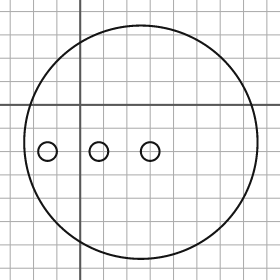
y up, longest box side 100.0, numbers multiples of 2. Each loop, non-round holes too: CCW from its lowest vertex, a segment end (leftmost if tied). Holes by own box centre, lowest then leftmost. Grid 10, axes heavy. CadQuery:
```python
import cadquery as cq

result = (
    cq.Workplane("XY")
    .moveTo(26.0, -16.0)
    .circle(50.0)
    .moveTo(-14.0, -20.0)
    .circle(4.0)
    .moveTo(8.0, -20.0)
    .circle(4.0)
    .moveTo(30.0, -20.0)
    .circle(4.0)
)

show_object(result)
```